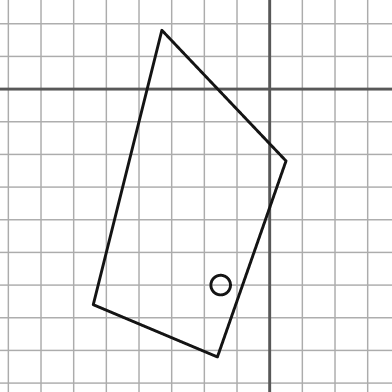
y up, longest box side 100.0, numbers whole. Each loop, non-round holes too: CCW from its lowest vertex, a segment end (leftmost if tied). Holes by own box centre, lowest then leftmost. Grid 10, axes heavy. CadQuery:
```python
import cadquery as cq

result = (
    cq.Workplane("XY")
    .moveTo(-16.0, -82.0)
    .lineTo(5.0, -22.0)
    .lineTo(-33.0, 18.0)
    .lineTo(-54.0, -66.0)
    .close()
    .moveTo(-15.0, -60.0)
    .circle(3.0)
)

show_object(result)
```